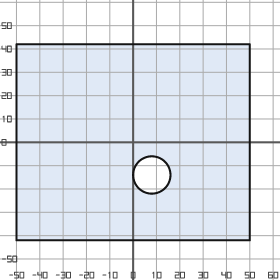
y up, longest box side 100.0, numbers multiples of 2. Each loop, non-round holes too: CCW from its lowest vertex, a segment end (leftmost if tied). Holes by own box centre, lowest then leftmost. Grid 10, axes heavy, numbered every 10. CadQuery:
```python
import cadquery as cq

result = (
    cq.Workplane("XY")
    .moveTo(-50.0, -42.0)
    .lineTo(50.0, -42.0)
    .lineTo(50.0, 42.0)
    .lineTo(-50.0, 42.0)
    .close()
    .moveTo(8.0, -14.0)
    .circle(8.0)
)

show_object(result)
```